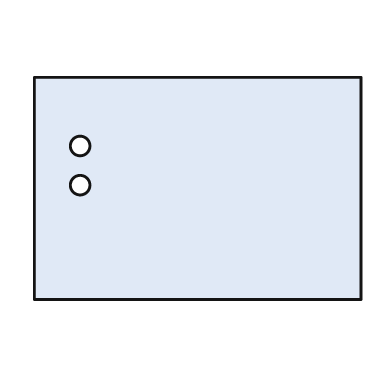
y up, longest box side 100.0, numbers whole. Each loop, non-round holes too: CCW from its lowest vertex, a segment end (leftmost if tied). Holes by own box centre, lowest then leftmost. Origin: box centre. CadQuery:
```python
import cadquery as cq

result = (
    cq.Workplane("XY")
    .moveTo(-50.0, -34.0)
    .lineTo(50.0, -34.0)
    .lineTo(50.0, 34.0)
    .lineTo(-50.0, 34.0)
    .close()
    .moveTo(-36.0, 1.0)
    .circle(3.0)
    .moveTo(-36.0, 13.0)
    .circle(3.0)
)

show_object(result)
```